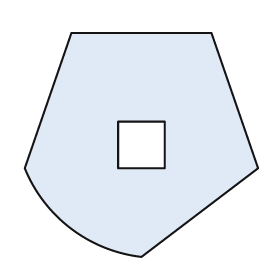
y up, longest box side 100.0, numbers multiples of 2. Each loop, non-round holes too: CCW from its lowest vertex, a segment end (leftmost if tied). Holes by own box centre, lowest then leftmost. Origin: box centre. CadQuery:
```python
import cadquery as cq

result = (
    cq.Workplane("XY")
    .moveTo(0.0, -48.0)
    .lineTo(50.0, -10.0)
    .lineTo(30.0, 48.0)
    .lineTo(-30.0, 48.0)
    .lineTo(-50.0, -10.0)
    .threePointArc((-30.0, -36.0), (0.0, -48.0))
    .close()
    .moveTo(-10.0, -10.0)
    .lineTo(10.0, -10.0)
    .lineTo(10.0, 10.0)
    .lineTo(-10.0, 10.0)
    .close()
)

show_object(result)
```